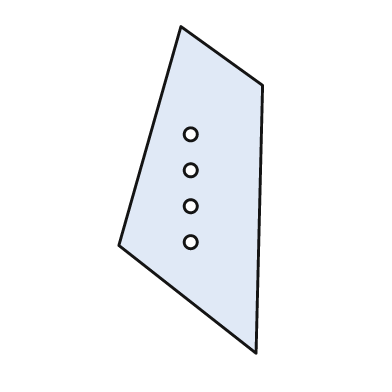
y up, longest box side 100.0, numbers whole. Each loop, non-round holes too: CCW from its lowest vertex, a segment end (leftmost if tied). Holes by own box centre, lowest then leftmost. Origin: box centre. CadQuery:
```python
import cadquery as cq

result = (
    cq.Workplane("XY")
    .moveTo(20.0, -50.0)
    .lineTo(22.0, 32.0)
    .lineTo(-3.0, 50.0)
    .lineTo(-22.0, -17.0)
    .close()
    .moveTo(0.0, -16.0)
    .circle(2.0)
    .moveTo(0.0, -5.0)
    .circle(2.0)
    .moveTo(0.0, 6.0)
    .circle(2.0)
    .moveTo(0.0, 17.0)
    .circle(2.0)
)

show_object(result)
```